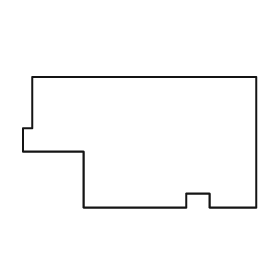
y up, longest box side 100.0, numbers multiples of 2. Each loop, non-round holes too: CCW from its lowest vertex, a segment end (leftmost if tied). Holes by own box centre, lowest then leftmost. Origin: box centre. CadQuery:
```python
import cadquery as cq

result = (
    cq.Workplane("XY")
    .moveTo(-24.0, -28.0)
    .lineTo(20.0, -28.0)
    .lineTo(20.0, -22.0)
    .lineTo(30.0, -22.0)
    .lineTo(30.0, -28.0)
    .lineTo(50.0, -28.0)
    .lineTo(50.0, 28.0)
    .lineTo(-46.0, 28.0)
    .lineTo(-46.0, 6.0)
    .lineTo(-50.0, 6.0)
    .lineTo(-50.0, -4.0)
    .lineTo(-24.0, -4.0)
    .close()
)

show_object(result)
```